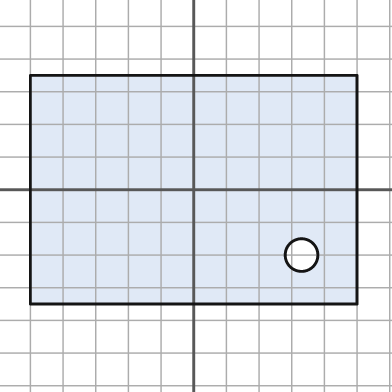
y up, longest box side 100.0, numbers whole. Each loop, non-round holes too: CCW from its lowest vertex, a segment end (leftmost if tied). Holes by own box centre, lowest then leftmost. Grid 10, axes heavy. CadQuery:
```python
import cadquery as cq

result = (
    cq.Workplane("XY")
    .moveTo(-50.0, -35.0)
    .lineTo(50.0, -35.0)
    .lineTo(50.0, 35.0)
    .lineTo(-50.0, 35.0)
    .close()
    .moveTo(33.0, -20.0)
    .circle(5.0)
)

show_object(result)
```